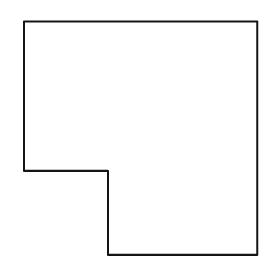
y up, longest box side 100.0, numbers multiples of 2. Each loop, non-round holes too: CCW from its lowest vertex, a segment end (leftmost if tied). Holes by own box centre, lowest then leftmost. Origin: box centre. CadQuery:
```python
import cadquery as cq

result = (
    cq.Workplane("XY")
    .moveTo(-14.0, -50.0)
    .lineTo(50.0, -50.0)
    .lineTo(50.0, 50.0)
    .lineTo(-50.0, 50.0)
    .lineTo(-50.0, -14.0)
    .lineTo(-14.0, -14.0)
    .close()
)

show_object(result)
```